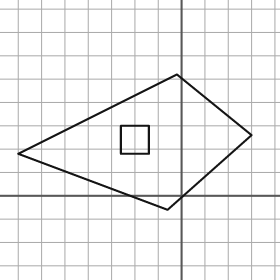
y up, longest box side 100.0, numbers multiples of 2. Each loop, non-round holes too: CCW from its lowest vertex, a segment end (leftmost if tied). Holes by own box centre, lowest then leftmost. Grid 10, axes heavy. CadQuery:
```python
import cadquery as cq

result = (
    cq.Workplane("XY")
    .moveTo(-6.0, -6.0)
    .lineTo(30.0, 26.0)
    .lineTo(-2.0, 52.0)
    .lineTo(-70.0, 18.0)
    .close()
    .moveTo(-26.0, 18.0)
    .lineTo(-14.0, 18.0)
    .lineTo(-14.0, 30.0)
    .lineTo(-26.0, 30.0)
    .close()
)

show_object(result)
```